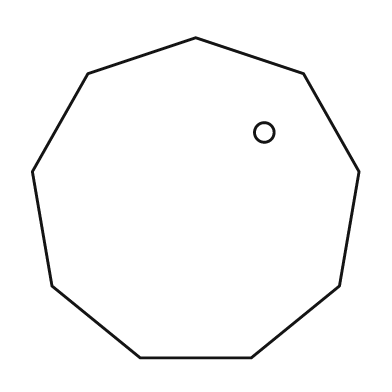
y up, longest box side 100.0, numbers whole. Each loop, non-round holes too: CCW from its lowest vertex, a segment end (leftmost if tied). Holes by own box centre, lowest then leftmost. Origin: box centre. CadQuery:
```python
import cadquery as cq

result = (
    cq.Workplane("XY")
    .moveTo(-17.0, -49.0)
    .lineTo(17.0, -49.0)
    .lineTo(44.0, -27.0)
    .lineTo(50.0, 8.0)
    .lineTo(33.0, 38.0)
    .lineTo(0.0, 49.0)
    .lineTo(-33.0, 38.0)
    .lineTo(-50.0, 8.0)
    .lineTo(-44.0, -27.0)
    .close()
    .moveTo(21.0, 20.0)
    .circle(3.0)
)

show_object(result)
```